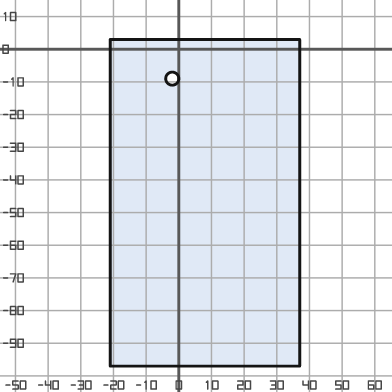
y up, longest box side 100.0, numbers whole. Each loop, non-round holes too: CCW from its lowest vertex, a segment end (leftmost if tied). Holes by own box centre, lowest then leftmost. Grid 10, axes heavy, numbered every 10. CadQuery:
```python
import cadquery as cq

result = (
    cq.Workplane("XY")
    .moveTo(-21.0, -97.0)
    .lineTo(37.0, -97.0)
    .lineTo(37.0, 3.0)
    .lineTo(-21.0, 3.0)
    .close()
    .moveTo(-2.0, -9.0)
    .circle(2.0)
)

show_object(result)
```